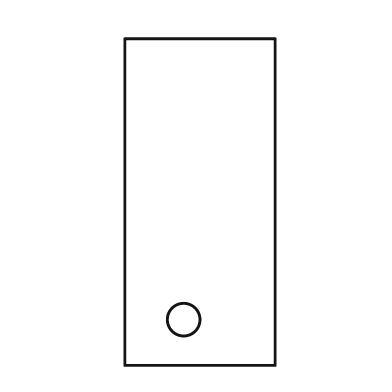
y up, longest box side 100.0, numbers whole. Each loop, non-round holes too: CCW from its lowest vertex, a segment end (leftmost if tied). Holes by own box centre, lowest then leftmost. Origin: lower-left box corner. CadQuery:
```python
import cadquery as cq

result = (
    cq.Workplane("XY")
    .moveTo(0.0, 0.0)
    .lineTo(46.0, 0.0)
    .lineTo(46.0, 100.0)
    .lineTo(0.0, 100.0)
    .close()
    .moveTo(18.0, 14.0)
    .circle(5.0)
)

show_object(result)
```